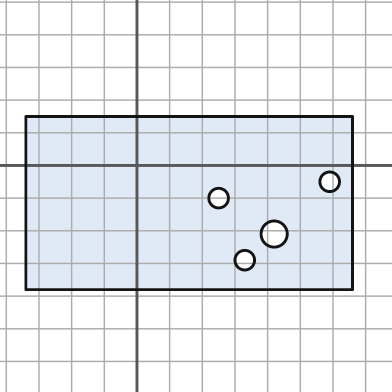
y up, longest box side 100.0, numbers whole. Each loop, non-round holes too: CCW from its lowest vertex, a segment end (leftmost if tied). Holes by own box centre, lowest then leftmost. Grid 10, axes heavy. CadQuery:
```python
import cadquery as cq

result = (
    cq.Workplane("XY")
    .moveTo(-34.0, -38.0)
    .lineTo(66.0, -38.0)
    .lineTo(66.0, 15.0)
    .lineTo(-34.0, 15.0)
    .close()
    .moveTo(33.0, -29.0)
    .circle(3.0)
    .moveTo(42.0, -21.0)
    .circle(4.0)
    .moveTo(25.0, -10.0)
    .circle(3.0)
    .moveTo(59.0, -5.0)
    .circle(3.0)
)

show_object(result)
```